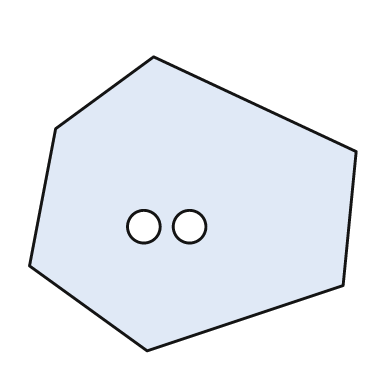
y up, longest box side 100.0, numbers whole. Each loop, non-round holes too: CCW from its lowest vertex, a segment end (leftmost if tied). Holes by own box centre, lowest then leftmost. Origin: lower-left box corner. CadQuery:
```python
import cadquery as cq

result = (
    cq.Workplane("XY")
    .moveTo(36.0, 0.0)
    .lineTo(96.0, 20.0)
    .lineTo(100.0, 61.0)
    .lineTo(38.0, 90.0)
    .lineTo(8.0, 68.0)
    .lineTo(0.0, 26.0)
    .close()
    .moveTo(35.0, 38.0)
    .circle(5.0)
    .moveTo(49.0, 38.0)
    .circle(5.0)
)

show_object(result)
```